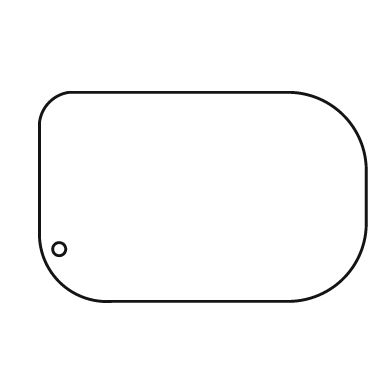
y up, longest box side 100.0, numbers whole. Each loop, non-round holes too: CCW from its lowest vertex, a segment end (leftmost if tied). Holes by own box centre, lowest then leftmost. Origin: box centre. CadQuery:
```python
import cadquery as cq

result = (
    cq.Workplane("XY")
    .moveTo(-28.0, -32.0)
    .lineTo(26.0, -32.0)
    .threePointArc((43.0, -25.0), (50.0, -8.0))
    .lineTo(50.0, 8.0)
    .threePointArc((43.0, 25.0), (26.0, 32.0))
    .lineTo(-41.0, 32.0)
    .threePointArc((-47.0, 29.0), (-50.0, 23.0))
    .lineTo(-50.0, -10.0)
    .threePointArc((-44.0, -26.0), (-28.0, -32.0))
    .close()
    .moveTo(-44.0, -16.0)
    .circle(2.0)
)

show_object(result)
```